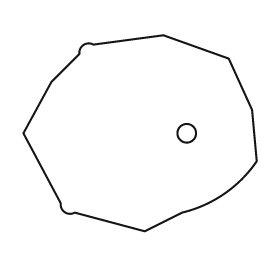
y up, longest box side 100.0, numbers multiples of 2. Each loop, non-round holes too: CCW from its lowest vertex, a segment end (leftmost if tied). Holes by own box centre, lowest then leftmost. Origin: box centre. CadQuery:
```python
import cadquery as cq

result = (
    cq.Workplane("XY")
    .moveTo(2.0, -42.0)
    .lineTo(18.0, -34.0)
    .threePointArc((36.0, -26.0), (50.0, -12.0))
    .lineTo(48.0, 10.0)
    .lineTo(38.0, 32.0)
    .lineTo(10.0, 42.0)
    .lineTo(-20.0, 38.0)
    .threePointArc((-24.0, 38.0), (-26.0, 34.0))
    .lineTo(-38.0, 22.0)
    .lineTo(-50.0, 0.0)
    .lineTo(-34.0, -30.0)
    .threePointArc((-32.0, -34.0), (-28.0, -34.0))
    .close()
    .moveTo(20.0, 0.0)
    .circle(4.0)
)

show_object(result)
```